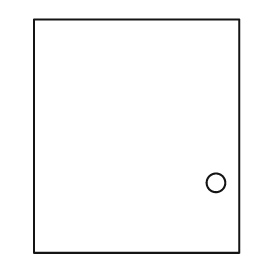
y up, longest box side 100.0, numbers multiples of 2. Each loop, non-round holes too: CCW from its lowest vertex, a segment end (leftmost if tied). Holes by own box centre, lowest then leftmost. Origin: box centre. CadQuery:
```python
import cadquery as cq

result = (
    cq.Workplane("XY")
    .moveTo(-44.0, -50.0)
    .lineTo(44.0, -50.0)
    .lineTo(44.0, 50.0)
    .lineTo(-44.0, 50.0)
    .close()
    .moveTo(34.0, -20.0)
    .circle(4.0)
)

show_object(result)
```